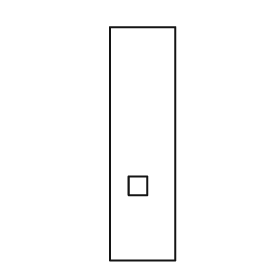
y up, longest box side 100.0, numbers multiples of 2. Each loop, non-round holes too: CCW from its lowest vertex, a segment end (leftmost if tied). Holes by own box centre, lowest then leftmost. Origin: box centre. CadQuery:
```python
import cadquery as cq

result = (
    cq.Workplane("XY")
    .moveTo(-14.0, -50.0)
    .lineTo(14.0, -50.0)
    .lineTo(14.0, 50.0)
    .lineTo(-14.0, 50.0)
    .close()
    .moveTo(-6.0, -22.0)
    .lineTo(2.0, -22.0)
    .lineTo(2.0, -14.0)
    .lineTo(-6.0, -14.0)
    .close()
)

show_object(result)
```